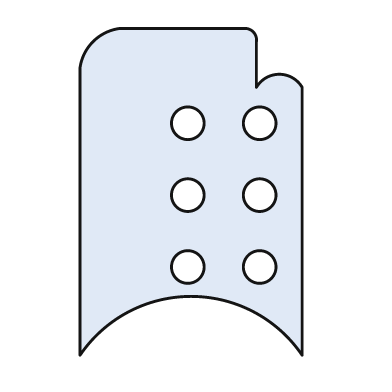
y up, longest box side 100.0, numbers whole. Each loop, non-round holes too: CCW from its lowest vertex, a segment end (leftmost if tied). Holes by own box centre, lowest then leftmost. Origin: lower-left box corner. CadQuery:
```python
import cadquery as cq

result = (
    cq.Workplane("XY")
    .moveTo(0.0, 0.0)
    .threePointArc((34.0, 18.0), (68.0, 0.0))
    .lineTo(68.0, 82.0)
    .threePointArc((61.0, 86.0), (54.0, 82.0))
    .lineTo(54.0, 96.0)
    .threePointArc((53.0, 99.0), (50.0, 100.0))
    .lineTo(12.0, 100.0)
    .threePointArc((4.0, 96.0), (0.0, 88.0))
    .close()
    .moveTo(33.0, 27.0)
    .circle(5.0)
    .moveTo(55.0, 27.0)
    .circle(5.0)
    .moveTo(33.0, 49.0)
    .circle(5.0)
    .moveTo(55.0, 49.0)
    .circle(5.0)
    .moveTo(33.0, 71.0)
    .circle(5.0)
    .moveTo(55.0, 71.0)
    .circle(5.0)
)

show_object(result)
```